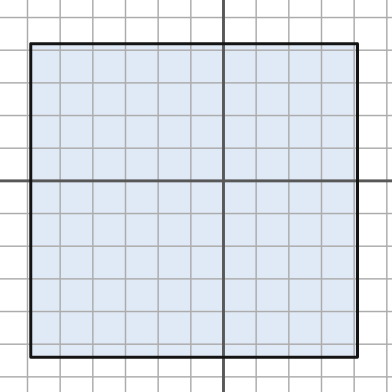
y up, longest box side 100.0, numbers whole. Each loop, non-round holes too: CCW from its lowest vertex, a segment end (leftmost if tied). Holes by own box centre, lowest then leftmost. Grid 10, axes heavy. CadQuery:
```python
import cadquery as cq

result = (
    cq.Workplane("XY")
    .moveTo(-59.0, -54.0)
    .lineTo(41.0, -54.0)
    .lineTo(41.0, 42.0)
    .lineTo(-59.0, 42.0)
    .close()
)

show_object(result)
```